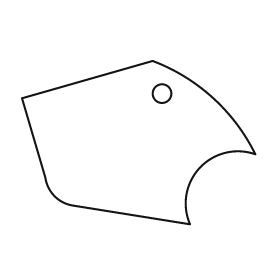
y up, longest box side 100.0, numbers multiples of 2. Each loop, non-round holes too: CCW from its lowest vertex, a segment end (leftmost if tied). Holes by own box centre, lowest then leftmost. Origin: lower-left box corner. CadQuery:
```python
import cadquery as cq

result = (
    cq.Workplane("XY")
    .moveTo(72.0, 0.0)
    .threePointArc((76.0, 24.0), (100.0, 30.0))
    .threePointArc((82.0, 54.0), (56.0, 70.0))
    .lineTo(0.0, 54.0)
    .lineTo(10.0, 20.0)
    .threePointArc((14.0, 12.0), (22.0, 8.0))
    .close()
    .moveTo(60.0, 56.0)
    .circle(4.0)
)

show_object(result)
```